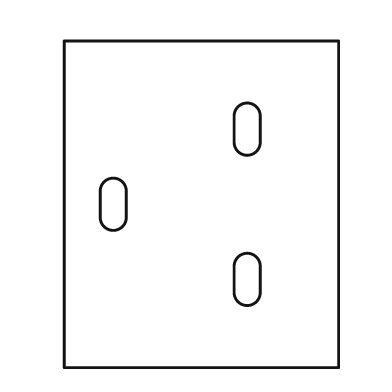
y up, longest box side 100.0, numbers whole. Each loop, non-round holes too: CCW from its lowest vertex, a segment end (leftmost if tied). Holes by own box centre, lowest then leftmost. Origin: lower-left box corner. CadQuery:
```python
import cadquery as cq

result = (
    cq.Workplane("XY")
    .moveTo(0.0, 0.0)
    .lineTo(84.0, 0.0)
    .lineTo(84.0, 100.0)
    .lineTo(0.0, 100.0)
    .close()
    .moveTo(52.0, 23.0)
    .threePointArc((56.0, 19.0), (60.0, 23.0))
    .lineTo(60.0, 31.0)
    .threePointArc((56.0, 35.0), (52.0, 31.0))
    .close()
    .moveTo(11.0, 46.0)
    .threePointArc((15.0, 42.0), (19.0, 46.0))
    .lineTo(19.0, 54.0)
    .threePointArc((15.0, 58.0), (11.0, 54.0))
    .close()
    .moveTo(52.0, 69.0)
    .threePointArc((56.0, 65.0), (60.0, 69.0))
    .lineTo(60.0, 77.0)
    .threePointArc((56.0, 81.0), (52.0, 77.0))
    .close()
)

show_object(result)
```